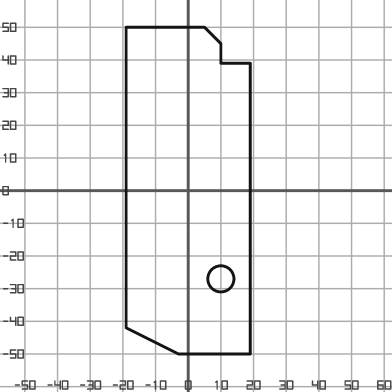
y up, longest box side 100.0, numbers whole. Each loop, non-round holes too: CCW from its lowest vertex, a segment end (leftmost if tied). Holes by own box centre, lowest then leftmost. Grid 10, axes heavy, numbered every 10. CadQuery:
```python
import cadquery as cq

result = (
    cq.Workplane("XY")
    .moveTo(-3.0, -50.0)
    .lineTo(19.0, -50.0)
    .lineTo(19.0, 39.0)
    .lineTo(10.0, 39.0)
    .lineTo(10.0, 45.0)
    .lineTo(5.0, 50.0)
    .lineTo(-19.0, 50.0)
    .lineTo(-19.0, -42.0)
    .close()
    .moveTo(10.0, -27.0)
    .circle(4.0)
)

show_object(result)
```